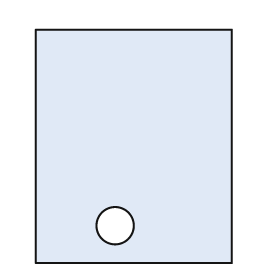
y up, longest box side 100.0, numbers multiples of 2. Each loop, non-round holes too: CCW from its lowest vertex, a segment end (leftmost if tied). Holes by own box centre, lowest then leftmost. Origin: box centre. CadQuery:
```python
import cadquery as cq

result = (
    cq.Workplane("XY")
    .moveTo(-42.0, -50.0)
    .lineTo(42.0, -50.0)
    .lineTo(42.0, 50.0)
    .lineTo(-42.0, 50.0)
    .close()
    .moveTo(-8.0, -34.0)
    .circle(8.0)
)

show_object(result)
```